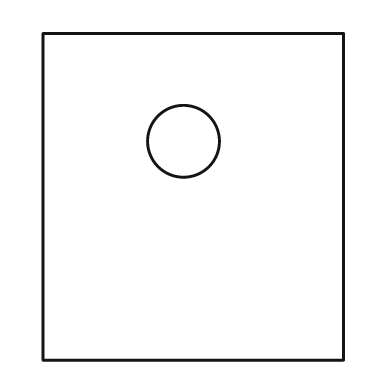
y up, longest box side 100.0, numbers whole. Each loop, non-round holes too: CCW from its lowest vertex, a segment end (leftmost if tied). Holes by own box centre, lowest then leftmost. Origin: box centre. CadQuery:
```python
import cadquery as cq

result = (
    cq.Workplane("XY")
    .moveTo(-46.0, -50.0)
    .lineTo(46.0, -50.0)
    .lineTo(46.0, 50.0)
    .lineTo(-46.0, 50.0)
    .close()
    .moveTo(-3.0, 17.0)
    .circle(11.0)
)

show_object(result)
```